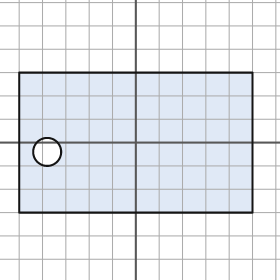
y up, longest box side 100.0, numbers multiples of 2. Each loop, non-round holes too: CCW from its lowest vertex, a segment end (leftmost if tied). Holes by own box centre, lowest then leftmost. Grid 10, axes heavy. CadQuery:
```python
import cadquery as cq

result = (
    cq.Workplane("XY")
    .moveTo(-50.0, -30.0)
    .lineTo(50.0, -30.0)
    .lineTo(50.0, 30.0)
    .lineTo(-50.0, 30.0)
    .close()
    .moveTo(-38.0, -4.0)
    .circle(6.0)
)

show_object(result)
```